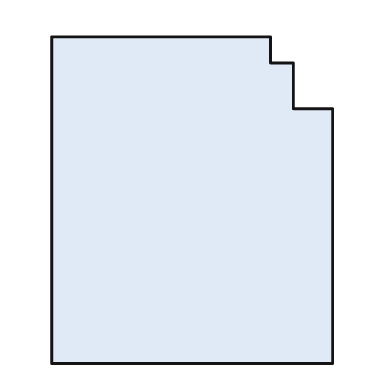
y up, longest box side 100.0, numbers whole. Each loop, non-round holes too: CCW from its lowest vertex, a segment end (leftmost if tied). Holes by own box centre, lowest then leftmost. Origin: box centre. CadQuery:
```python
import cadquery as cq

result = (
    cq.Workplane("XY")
    .moveTo(-43.0, -50.0)
    .lineTo(43.0, -50.0)
    .lineTo(43.0, 28.0)
    .lineTo(31.0, 28.0)
    .lineTo(31.0, 42.0)
    .lineTo(24.0, 42.0)
    .lineTo(24.0, 50.0)
    .lineTo(-43.0, 50.0)
    .close()
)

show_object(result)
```